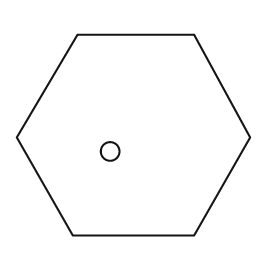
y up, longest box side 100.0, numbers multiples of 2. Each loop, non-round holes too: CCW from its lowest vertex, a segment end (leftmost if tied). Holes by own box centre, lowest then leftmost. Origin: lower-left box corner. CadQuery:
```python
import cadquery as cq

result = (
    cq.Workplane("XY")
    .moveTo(24.0, 0.0)
    .lineTo(76.0, 0.0)
    .lineTo(100.0, 42.0)
    .lineTo(76.0, 86.0)
    .lineTo(26.0, 86.0)
    .lineTo(0.0, 42.0)
    .close()
    .moveTo(40.0, 36.0)
    .circle(4.0)
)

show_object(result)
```